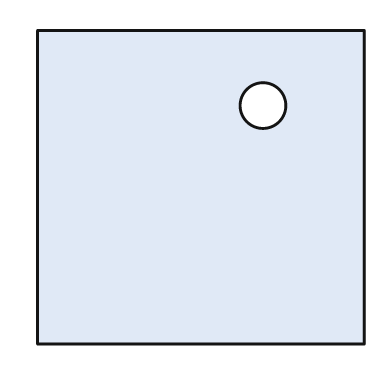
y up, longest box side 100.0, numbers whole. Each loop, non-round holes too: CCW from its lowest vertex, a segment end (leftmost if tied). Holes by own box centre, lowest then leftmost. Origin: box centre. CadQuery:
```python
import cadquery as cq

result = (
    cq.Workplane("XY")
    .moveTo(-50.0, -48.0)
    .lineTo(50.0, -48.0)
    .lineTo(50.0, 48.0)
    .lineTo(-50.0, 48.0)
    .close()
    .moveTo(19.0, 25.0)
    .circle(7.0)
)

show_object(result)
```